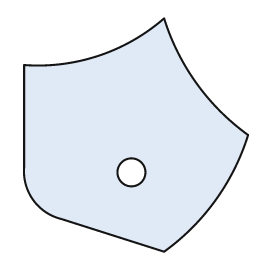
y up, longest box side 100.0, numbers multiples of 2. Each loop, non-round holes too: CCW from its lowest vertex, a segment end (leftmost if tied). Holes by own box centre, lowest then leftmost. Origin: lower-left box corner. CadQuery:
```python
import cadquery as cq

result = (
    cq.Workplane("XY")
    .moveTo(60.0, 0.0)
    .threePointArc((82.0, 22.0), (96.0, 50.0))
    .threePointArc((74.0, 72.0), (60.0, 100.0))
    .threePointArc((32.0, 84.0), (0.0, 80.0))
    .lineTo(0.0, 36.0)
    .threePointArc((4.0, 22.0), (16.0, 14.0))
    .close()
    .moveTo(46.0, 34.0)
    .circle(6.0)
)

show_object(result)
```